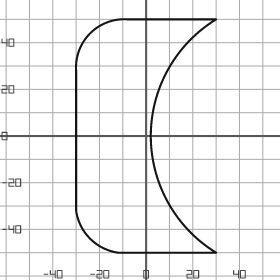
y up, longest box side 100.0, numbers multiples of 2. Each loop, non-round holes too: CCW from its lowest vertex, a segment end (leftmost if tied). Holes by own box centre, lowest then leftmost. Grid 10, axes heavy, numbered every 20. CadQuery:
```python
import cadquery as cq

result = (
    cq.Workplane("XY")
    .moveTo(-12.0, -50.0)
    .lineTo(30.0, -50.0)
    .threePointArc((2.0, 0.0), (30.0, 50.0))
    .lineTo(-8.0, 50.0)
    .threePointArc((-24.0, 44.0), (-30.0, 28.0))
    .lineTo(-30.0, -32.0)
    .threePointArc((-24.0, -44.0), (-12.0, -50.0))
    .close()
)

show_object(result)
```